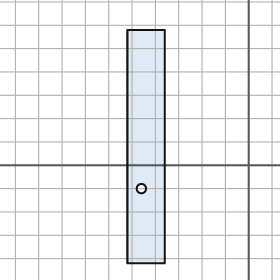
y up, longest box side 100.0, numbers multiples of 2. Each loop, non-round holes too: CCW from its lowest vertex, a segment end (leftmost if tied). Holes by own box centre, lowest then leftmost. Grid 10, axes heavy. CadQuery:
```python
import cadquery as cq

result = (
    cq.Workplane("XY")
    .moveTo(-52.0, -42.0)
    .lineTo(-36.0, -42.0)
    .lineTo(-36.0, 58.0)
    .lineTo(-52.0, 58.0)
    .close()
    .moveTo(-46.0, -10.0)
    .circle(2.0)
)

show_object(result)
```